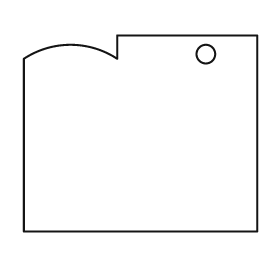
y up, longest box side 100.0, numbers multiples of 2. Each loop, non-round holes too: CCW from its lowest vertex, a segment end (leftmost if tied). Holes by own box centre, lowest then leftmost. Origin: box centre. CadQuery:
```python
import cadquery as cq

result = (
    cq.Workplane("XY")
    .moveTo(-50.0, -42.0)
    .lineTo(50.0, -42.0)
    .lineTo(50.0, 42.0)
    .lineTo(-10.0, 42.0)
    .lineTo(-10.0, 32.0)
    .threePointArc((-30.0, 38.0), (-50.0, 32.0))
    .close()
    .moveTo(28.0, 34.0)
    .circle(4.0)
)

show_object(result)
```